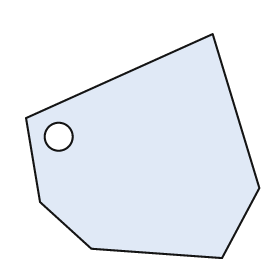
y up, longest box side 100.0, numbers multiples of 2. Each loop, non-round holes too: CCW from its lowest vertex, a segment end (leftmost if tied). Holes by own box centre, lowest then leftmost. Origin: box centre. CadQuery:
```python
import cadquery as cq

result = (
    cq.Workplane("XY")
    .moveTo(34.0, -48.0)
    .lineTo(50.0, -18.0)
    .lineTo(30.0, 48.0)
    .lineTo(-50.0, 12.0)
    .lineTo(-44.0, -24.0)
    .lineTo(-22.0, -44.0)
    .close()
    .moveTo(-36.0, 4.0)
    .circle(6.0)
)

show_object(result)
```